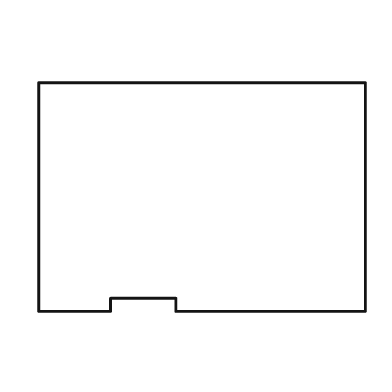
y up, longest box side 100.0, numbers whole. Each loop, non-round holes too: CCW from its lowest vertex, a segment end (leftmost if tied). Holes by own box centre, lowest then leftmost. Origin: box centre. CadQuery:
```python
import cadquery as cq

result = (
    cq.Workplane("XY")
    .moveTo(-50.0, -35.0)
    .lineTo(-28.0, -35.0)
    .lineTo(-28.0, -31.0)
    .lineTo(-8.0, -31.0)
    .lineTo(-8.0, -35.0)
    .lineTo(50.0, -35.0)
    .lineTo(50.0, 35.0)
    .lineTo(-50.0, 35.0)
    .close()
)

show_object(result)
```